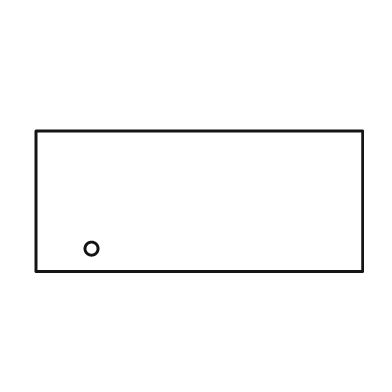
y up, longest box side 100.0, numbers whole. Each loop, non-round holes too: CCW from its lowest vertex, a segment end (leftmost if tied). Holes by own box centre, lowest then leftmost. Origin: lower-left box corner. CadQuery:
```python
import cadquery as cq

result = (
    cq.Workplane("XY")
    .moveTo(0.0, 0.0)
    .lineTo(100.0, 0.0)
    .lineTo(100.0, 43.0)
    .lineTo(0.0, 43.0)
    .close()
    .moveTo(17.0, 7.0)
    .circle(2.0)
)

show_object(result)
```